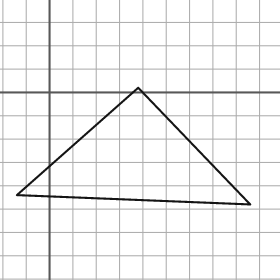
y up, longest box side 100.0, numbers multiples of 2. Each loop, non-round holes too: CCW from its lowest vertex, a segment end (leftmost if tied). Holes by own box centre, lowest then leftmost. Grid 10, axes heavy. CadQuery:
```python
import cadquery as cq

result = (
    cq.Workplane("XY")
    .moveTo(86.0, -48.0)
    .lineTo(38.0, 2.0)
    .lineTo(-14.0, -44.0)
    .close()
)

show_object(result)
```